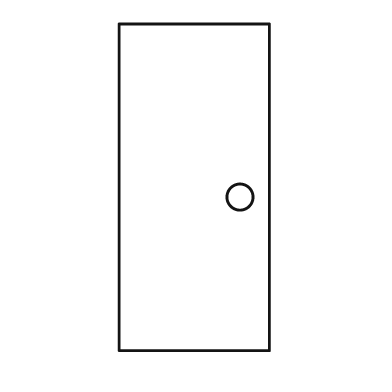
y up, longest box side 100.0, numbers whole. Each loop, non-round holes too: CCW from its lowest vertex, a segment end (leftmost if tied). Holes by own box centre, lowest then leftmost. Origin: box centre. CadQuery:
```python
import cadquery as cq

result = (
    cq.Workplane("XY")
    .moveTo(-23.0, -50.0)
    .lineTo(23.0, -50.0)
    .lineTo(23.0, 50.0)
    .lineTo(-23.0, 50.0)
    .close()
    .moveTo(14.0, -3.0)
    .circle(4.0)
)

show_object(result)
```